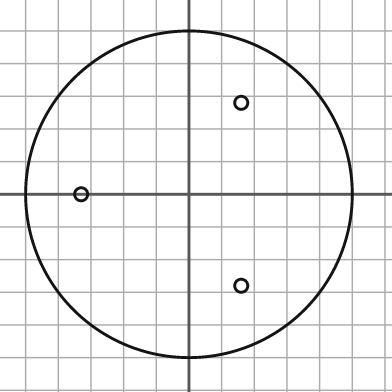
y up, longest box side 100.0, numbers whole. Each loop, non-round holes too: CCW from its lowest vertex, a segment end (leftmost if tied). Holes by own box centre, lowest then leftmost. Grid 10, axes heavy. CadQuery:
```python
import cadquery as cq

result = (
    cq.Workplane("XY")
    .moveTo(0.0, 0.0)
    .circle(50.0)
    .moveTo(16.0, -28.0)
    .circle(2.0)
    .moveTo(-33.0, 0.0)
    .circle(2.0)
    .moveTo(16.0, 28.0)
    .circle(2.0)
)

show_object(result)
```